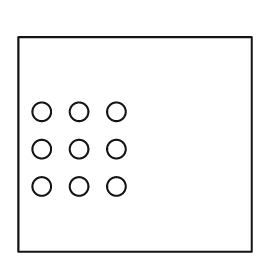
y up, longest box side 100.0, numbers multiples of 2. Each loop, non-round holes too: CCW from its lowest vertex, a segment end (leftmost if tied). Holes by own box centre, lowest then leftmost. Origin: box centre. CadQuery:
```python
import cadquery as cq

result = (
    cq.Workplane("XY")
    .moveTo(-50.0, -46.0)
    .lineTo(50.0, -46.0)
    .lineTo(50.0, 46.0)
    .lineTo(-50.0, 46.0)
    .close()
    .moveTo(-40.0, -18.0)
    .circle(4.0)
    .moveTo(-24.0, -18.0)
    .circle(4.0)
    .moveTo(-8.0, -18.0)
    .circle(4.0)
    .moveTo(-40.0, -2.0)
    .circle(4.0)
    .moveTo(-24.0, -2.0)
    .circle(4.0)
    .moveTo(-8.0, -2.0)
    .circle(4.0)
    .moveTo(-40.0, 14.0)
    .circle(4.0)
    .moveTo(-24.0, 14.0)
    .circle(4.0)
    .moveTo(-8.0, 14.0)
    .circle(4.0)
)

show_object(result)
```